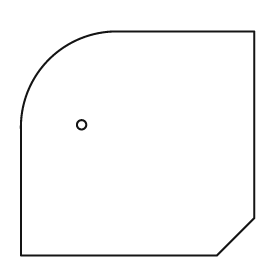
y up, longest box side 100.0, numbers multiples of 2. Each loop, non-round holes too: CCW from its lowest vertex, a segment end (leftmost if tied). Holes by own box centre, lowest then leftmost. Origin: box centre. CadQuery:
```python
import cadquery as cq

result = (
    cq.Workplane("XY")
    .moveTo(-50.0, -48.0)
    .lineTo(34.0, -48.0)
    .lineTo(50.0, -32.0)
    .lineTo(50.0, 48.0)
    .lineTo(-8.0, 48.0)
    .threePointArc((-38.0, 36.0), (-50.0, 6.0))
    .close()
    .moveTo(-24.0, 8.0)
    .circle(2.0)
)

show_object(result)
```